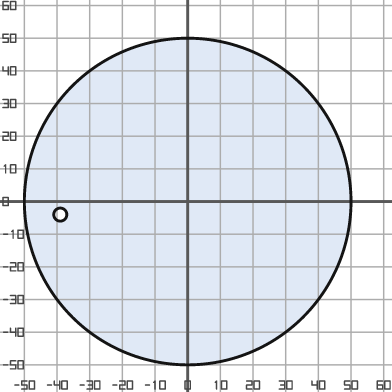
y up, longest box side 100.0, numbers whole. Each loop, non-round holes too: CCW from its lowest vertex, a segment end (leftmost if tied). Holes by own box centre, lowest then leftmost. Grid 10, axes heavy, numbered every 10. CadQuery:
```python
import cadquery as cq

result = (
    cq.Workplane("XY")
    .moveTo(0.0, 0.0)
    .circle(50.0)
    .moveTo(-39.0, -4.0)
    .circle(2.0)
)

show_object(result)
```